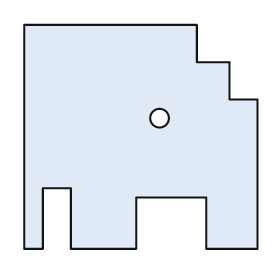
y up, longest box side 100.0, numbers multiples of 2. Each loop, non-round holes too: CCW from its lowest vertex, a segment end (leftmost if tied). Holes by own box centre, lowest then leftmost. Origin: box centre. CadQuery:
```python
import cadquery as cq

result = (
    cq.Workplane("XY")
    .moveTo(-50.0, -48.0)
    .lineTo(-42.0, -48.0)
    .lineTo(-42.0, -22.0)
    .lineTo(-30.0, -22.0)
    .lineTo(-30.0, -48.0)
    .lineTo(-2.0, -48.0)
    .lineTo(-2.0, -26.0)
    .lineTo(28.0, -26.0)
    .lineTo(28.0, -48.0)
    .lineTo(50.0, -48.0)
    .lineTo(50.0, 16.0)
    .lineTo(38.0, 16.0)
    .lineTo(38.0, 32.0)
    .lineTo(24.0, 32.0)
    .lineTo(24.0, 48.0)
    .lineTo(-50.0, 48.0)
    .close()
    .moveTo(8.0, 8.0)
    .circle(4.0)
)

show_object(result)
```